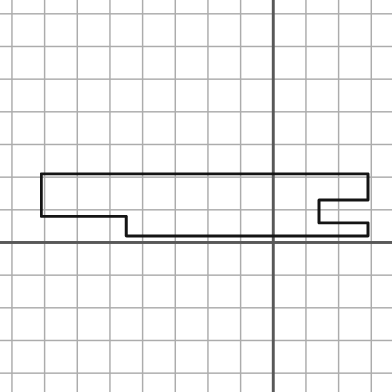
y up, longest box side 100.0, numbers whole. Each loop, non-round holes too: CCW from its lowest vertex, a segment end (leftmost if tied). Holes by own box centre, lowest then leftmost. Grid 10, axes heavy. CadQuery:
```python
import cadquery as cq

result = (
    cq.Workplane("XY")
    .moveTo(-45.0, 2.0)
    .lineTo(29.0, 2.0)
    .lineTo(29.0, 6.0)
    .lineTo(14.0, 6.0)
    .lineTo(14.0, 13.0)
    .lineTo(29.0, 13.0)
    .lineTo(29.0, 21.0)
    .lineTo(-71.0, 21.0)
    .lineTo(-71.0, 8.0)
    .lineTo(-45.0, 8.0)
    .close()
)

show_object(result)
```